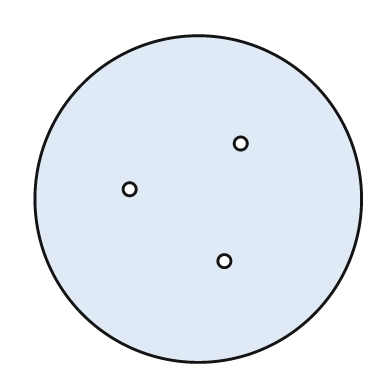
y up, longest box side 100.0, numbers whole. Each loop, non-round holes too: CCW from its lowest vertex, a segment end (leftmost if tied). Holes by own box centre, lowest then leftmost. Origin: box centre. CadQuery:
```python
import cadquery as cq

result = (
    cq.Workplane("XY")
    .moveTo(0.0, 0.0)
    .circle(50.0)
    .moveTo(8.0, -19.0)
    .circle(2.0)
    .moveTo(-21.0, 3.0)
    .circle(2.0)
    .moveTo(13.0, 17.0)
    .circle(2.0)
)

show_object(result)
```